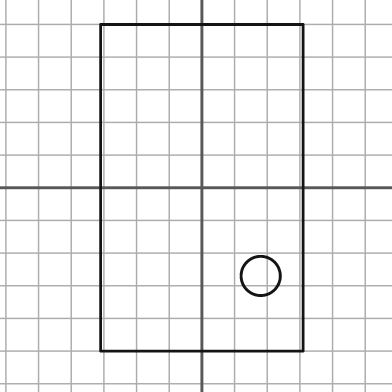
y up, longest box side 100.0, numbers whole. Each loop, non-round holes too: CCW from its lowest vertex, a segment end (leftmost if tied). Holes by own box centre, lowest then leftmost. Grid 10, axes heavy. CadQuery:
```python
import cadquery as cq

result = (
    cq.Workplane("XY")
    .moveTo(-31.0, -50.0)
    .lineTo(31.0, -50.0)
    .lineTo(31.0, 50.0)
    .lineTo(-31.0, 50.0)
    .close()
    .moveTo(18.0, -27.0)
    .circle(6.0)
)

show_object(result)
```